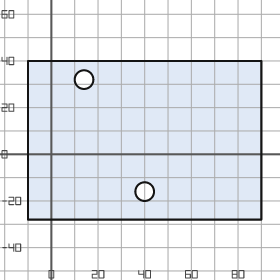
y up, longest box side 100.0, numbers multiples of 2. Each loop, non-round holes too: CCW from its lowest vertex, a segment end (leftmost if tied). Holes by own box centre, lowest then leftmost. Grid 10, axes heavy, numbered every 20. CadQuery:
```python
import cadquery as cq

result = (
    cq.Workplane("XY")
    .moveTo(-10.0, -28.0)
    .lineTo(90.0, -28.0)
    .lineTo(90.0, 40.0)
    .lineTo(-10.0, 40.0)
    .close()
    .moveTo(40.0, -16.0)
    .circle(4.0)
    .moveTo(14.0, 32.0)
    .circle(4.0)
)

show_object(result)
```